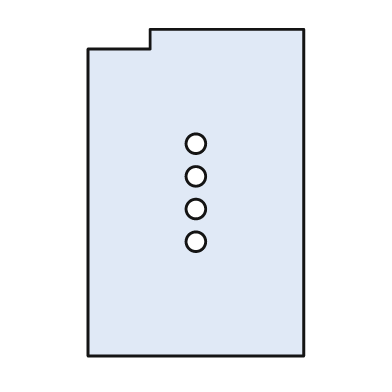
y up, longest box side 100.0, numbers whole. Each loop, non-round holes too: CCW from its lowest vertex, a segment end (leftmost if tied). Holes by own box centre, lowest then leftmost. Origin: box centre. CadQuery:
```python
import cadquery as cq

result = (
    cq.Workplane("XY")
    .moveTo(-33.0, -50.0)
    .lineTo(33.0, -50.0)
    .lineTo(33.0, 50.0)
    .lineTo(-14.0, 50.0)
    .lineTo(-14.0, 44.0)
    .lineTo(-33.0, 44.0)
    .close()
    .moveTo(0.0, -15.0)
    .circle(3.0)
    .moveTo(0.0, -5.0)
    .circle(3.0)
    .moveTo(0.0, 5.0)
    .circle(3.0)
    .moveTo(0.0, 15.0)
    .circle(3.0)
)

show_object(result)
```